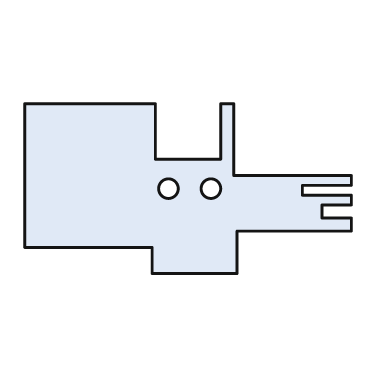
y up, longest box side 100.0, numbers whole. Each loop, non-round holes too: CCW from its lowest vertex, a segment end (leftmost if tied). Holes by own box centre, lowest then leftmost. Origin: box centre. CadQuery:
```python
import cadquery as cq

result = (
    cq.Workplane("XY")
    .moveTo(-11.0, -26.0)
    .lineTo(15.0, -26.0)
    .lineTo(15.0, -13.0)
    .lineTo(50.0, -13.0)
    .lineTo(50.0, -9.0)
    .lineTo(41.0, -9.0)
    .lineTo(41.0, -5.0)
    .lineTo(50.0, -5.0)
    .lineTo(50.0, -2.0)
    .lineTo(35.0, -2.0)
    .lineTo(35.0, 1.0)
    .lineTo(50.0, 1.0)
    .lineTo(50.0, 4.0)
    .lineTo(14.0, 4.0)
    .lineTo(14.0, 26.0)
    .lineTo(10.0, 26.0)
    .lineTo(10.0, 9.0)
    .lineTo(-10.0, 9.0)
    .lineTo(-10.0, 26.0)
    .lineTo(-50.0, 26.0)
    .lineTo(-50.0, -18.0)
    .lineTo(-11.0, -18.0)
    .close()
    .moveTo(-6.0, 0.0)
    .circle(3.0)
    .moveTo(7.0, 0.0)
    .circle(3.0)
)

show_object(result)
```